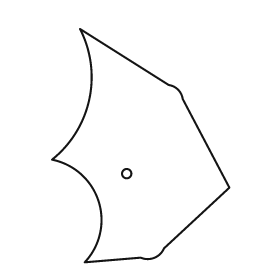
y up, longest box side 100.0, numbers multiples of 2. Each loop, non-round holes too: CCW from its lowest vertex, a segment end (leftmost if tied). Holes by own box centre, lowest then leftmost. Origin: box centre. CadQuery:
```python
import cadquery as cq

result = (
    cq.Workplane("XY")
    .moveTo(-24.0, -50.0)
    .lineTo(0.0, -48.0)
    .threePointArc((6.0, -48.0), (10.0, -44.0))
    .lineTo(38.0, -18.0)
    .lineTo(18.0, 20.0)
    .threePointArc((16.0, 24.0), (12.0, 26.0))
    .lineTo(-26.0, 50.0)
    .threePointArc((-22.0, 20.0), (-38.0, -6.0))
    .threePointArc((-18.0, -24.0), (-24.0, -50.0))
    .close()
    .moveTo(-6.0, -12.0)
    .circle(2.0)
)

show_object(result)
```